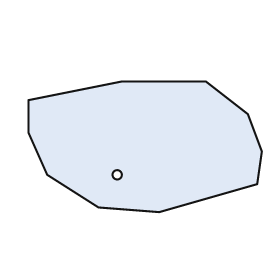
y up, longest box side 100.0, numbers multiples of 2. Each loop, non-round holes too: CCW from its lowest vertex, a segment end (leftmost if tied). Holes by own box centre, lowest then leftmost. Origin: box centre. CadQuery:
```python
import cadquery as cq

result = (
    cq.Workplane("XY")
    .moveTo(6.0, -28.0)
    .lineTo(48.0, -16.0)
    .lineTo(50.0, -2.0)
    .lineTo(44.0, 14.0)
    .lineTo(26.0, 28.0)
    .lineTo(-10.0, 28.0)
    .lineTo(-50.0, 20.0)
    .lineTo(-50.0, 6.0)
    .lineTo(-42.0, -12.0)
    .lineTo(-20.0, -26.0)
    .close()
    .moveTo(-12.0, -12.0)
    .circle(2.0)
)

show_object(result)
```